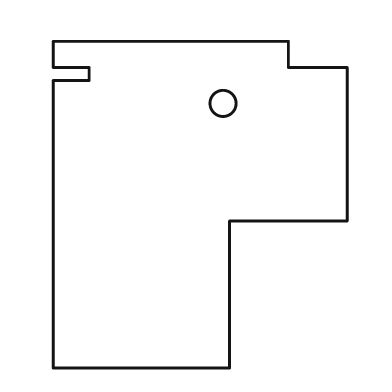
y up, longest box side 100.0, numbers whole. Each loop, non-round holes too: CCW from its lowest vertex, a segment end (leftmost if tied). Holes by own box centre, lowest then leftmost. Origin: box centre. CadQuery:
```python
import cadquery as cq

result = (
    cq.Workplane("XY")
    .moveTo(-45.0, -50.0)
    .lineTo(9.0, -50.0)
    .lineTo(9.0, -5.0)
    .lineTo(45.0, -5.0)
    .lineTo(45.0, 42.0)
    .lineTo(27.0, 42.0)
    .lineTo(27.0, 50.0)
    .lineTo(-45.0, 50.0)
    .lineTo(-45.0, 42.0)
    .lineTo(-34.0, 42.0)
    .lineTo(-34.0, 38.0)
    .lineTo(-45.0, 38.0)
    .close()
    .moveTo(7.0, 31.0)
    .circle(4.0)
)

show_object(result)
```